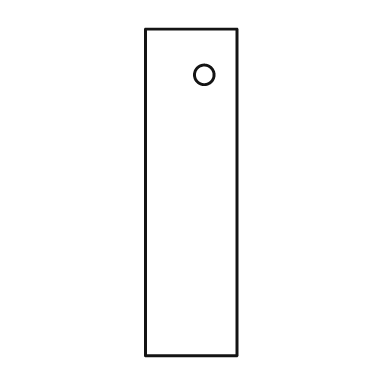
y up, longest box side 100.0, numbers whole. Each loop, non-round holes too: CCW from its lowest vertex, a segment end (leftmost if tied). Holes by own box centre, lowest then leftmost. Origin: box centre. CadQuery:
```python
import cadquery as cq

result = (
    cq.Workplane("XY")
    .moveTo(-14.0, -50.0)
    .lineTo(14.0, -50.0)
    .lineTo(14.0, 50.0)
    .lineTo(-14.0, 50.0)
    .close()
    .moveTo(4.0, 36.0)
    .circle(3.0)
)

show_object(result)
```